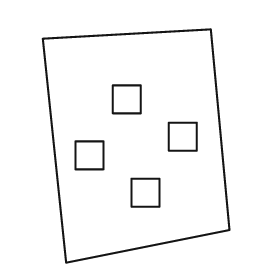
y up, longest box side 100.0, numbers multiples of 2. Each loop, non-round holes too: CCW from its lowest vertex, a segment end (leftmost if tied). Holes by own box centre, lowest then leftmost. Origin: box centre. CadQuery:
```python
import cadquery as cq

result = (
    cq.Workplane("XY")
    .moveTo(-30.0, -50.0)
    .lineTo(40.0, -36.0)
    .lineTo(32.0, 50.0)
    .lineTo(-40.0, 46.0)
    .close()
    .moveTo(-2.0, -26.0)
    .lineTo(10.0, -26.0)
    .lineTo(10.0, -14.0)
    .lineTo(-2.0, -14.0)
    .close()
    .moveTo(-26.0, -10.0)
    .lineTo(-14.0, -10.0)
    .lineTo(-14.0, 2.0)
    .lineTo(-26.0, 2.0)
    .close()
    .moveTo(14.0, -2.0)
    .lineTo(26.0, -2.0)
    .lineTo(26.0, 10.0)
    .lineTo(14.0, 10.0)
    .close()
    .moveTo(-10.0, 14.0)
    .lineTo(2.0, 14.0)
    .lineTo(2.0, 26.0)
    .lineTo(-10.0, 26.0)
    .close()
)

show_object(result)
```